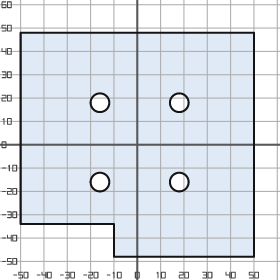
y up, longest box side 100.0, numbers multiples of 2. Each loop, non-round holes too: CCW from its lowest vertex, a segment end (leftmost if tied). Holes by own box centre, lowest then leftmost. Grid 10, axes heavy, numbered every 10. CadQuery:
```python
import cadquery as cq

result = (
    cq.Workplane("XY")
    .moveTo(-10.0, -48.0)
    .lineTo(50.0, -48.0)
    .lineTo(50.0, 48.0)
    .lineTo(-50.0, 48.0)
    .lineTo(-50.0, -34.0)
    .lineTo(-10.0, -34.0)
    .close()
    .moveTo(-16.0, -16.0)
    .circle(4.0)
    .moveTo(18.0, -16.0)
    .circle(4.0)
    .moveTo(-16.0, 18.0)
    .circle(4.0)
    .moveTo(18.0, 18.0)
    .circle(4.0)
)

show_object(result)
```